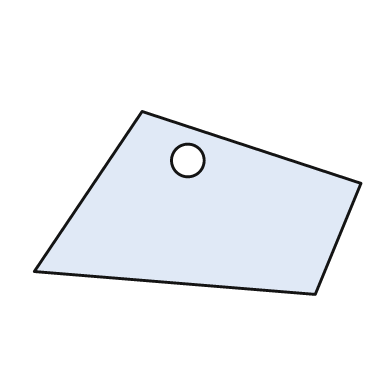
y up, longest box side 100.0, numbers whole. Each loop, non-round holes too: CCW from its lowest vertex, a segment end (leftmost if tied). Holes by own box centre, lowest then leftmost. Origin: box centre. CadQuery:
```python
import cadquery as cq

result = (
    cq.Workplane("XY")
    .moveTo(36.0, -28.0)
    .lineTo(50.0, 6.0)
    .lineTo(-17.0, 28.0)
    .lineTo(-50.0, -21.0)
    .close()
    .moveTo(-3.0, 13.0)
    .circle(5.0)
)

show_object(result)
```